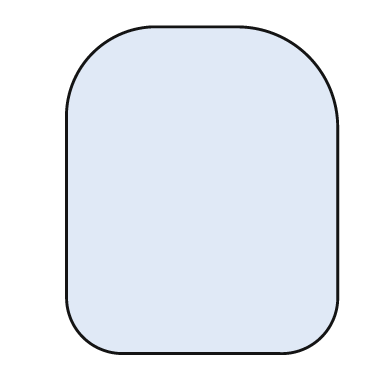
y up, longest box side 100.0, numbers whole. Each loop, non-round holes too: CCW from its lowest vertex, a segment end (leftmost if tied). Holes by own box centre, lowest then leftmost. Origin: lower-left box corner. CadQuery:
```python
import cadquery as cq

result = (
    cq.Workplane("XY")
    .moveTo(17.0, 0.0)
    .lineTo(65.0, 0.0)
    .threePointArc((78.0, 5.0), (83.0, 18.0))
    .lineTo(83.0, 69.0)
    .threePointArc((74.0, 91.0), (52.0, 100.0))
    .lineTo(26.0, 100.0)
    .threePointArc((8.0, 92.0), (0.0, 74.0))
    .lineTo(0.0, 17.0)
    .threePointArc((5.0, 5.0), (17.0, 0.0))
    .close()
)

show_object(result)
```